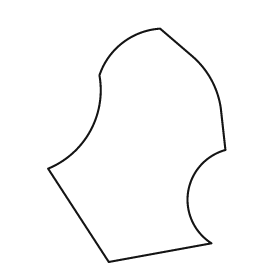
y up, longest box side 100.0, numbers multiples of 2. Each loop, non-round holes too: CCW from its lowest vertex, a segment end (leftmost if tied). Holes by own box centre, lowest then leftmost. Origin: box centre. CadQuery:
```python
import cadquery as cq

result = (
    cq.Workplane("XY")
    .moveTo(-12.0, -50.0)
    .lineTo(32.0, -42.0)
    .threePointArc((22.0, -20.0), (38.0, -2.0))
    .lineTo(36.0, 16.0)
    .threePointArc((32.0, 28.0), (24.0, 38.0))
    .lineTo(10.0, 50.0)
    .threePointArc((-6.0, 44.0), (-16.0, 30.0))
    .threePointArc((-20.0, 6.0), (-38.0, -10.0))
    .close()
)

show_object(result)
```